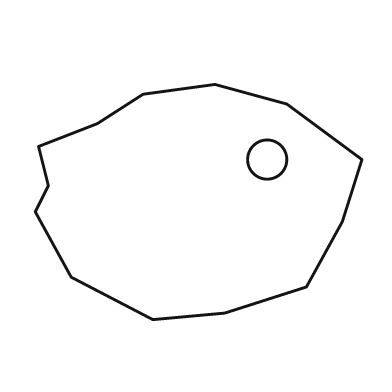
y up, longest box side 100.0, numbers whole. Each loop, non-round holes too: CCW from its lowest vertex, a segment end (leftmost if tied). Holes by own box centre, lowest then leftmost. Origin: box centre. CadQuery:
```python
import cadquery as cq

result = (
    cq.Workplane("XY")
    .moveTo(-14.0, -36.0)
    .lineTo(8.0, -34.0)
    .lineTo(33.0, -26.0)
    .lineTo(44.0, -6.0)
    .lineTo(50.0, 13.0)
    .lineTo(27.0, 30.0)
    .lineTo(5.0, 36.0)
    .lineTo(-17.0, 33.0)
    .lineTo(-31.0, 24.0)
    .lineTo(-49.0, 17.0)
    .lineTo(-46.0, 5.0)
    .lineTo(-50.0, -3.0)
    .lineTo(-39.0, -23.0)
    .close()
    .moveTo(21.0, 13.0)
    .circle(6.0)
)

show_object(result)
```